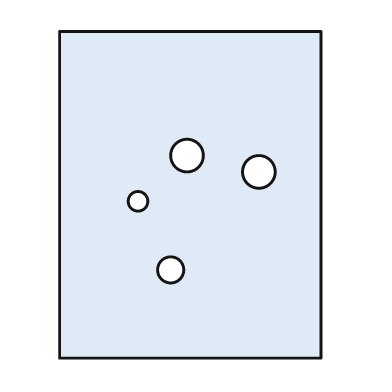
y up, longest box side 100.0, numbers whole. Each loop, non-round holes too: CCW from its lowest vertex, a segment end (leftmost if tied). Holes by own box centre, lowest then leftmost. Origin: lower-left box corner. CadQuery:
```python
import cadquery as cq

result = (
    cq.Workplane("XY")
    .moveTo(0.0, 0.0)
    .lineTo(80.0, 0.0)
    .lineTo(80.0, 100.0)
    .lineTo(0.0, 100.0)
    .close()
    .moveTo(34.0, 27.0)
    .circle(4.0)
    .moveTo(24.0, 48.0)
    .circle(3.0)
    .moveTo(61.0, 57.0)
    .circle(5.0)
    .moveTo(39.0, 62.0)
    .circle(5.0)
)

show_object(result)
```